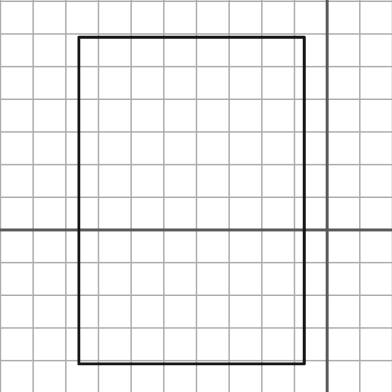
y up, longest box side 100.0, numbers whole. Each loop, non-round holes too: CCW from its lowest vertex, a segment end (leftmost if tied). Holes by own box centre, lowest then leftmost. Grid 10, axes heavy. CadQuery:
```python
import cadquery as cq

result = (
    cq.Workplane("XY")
    .moveTo(-76.0, -41.0)
    .lineTo(-7.0, -41.0)
    .lineTo(-7.0, 59.0)
    .lineTo(-76.0, 59.0)
    .close()
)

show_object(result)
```